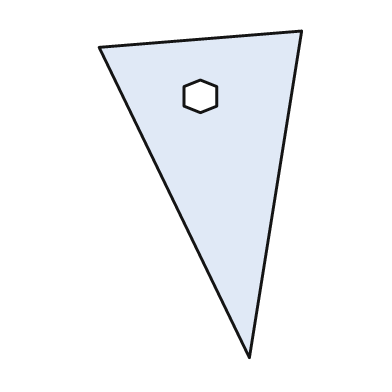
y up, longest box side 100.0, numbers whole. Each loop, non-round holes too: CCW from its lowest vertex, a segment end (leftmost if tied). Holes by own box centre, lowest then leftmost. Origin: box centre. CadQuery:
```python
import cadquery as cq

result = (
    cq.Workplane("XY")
    .moveTo(15.0, -50.0)
    .lineTo(31.0, 50.0)
    .lineTo(-31.0, 45.0)
    .close()
    .moveTo(0.0, 25.0)
    .lineTo(5.0, 27.0)
    .lineTo(5.0, 33.0)
    .lineTo(0.0, 35.0)
    .lineTo(-5.0, 33.0)
    .lineTo(-5.0, 27.0)
    .close()
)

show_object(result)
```